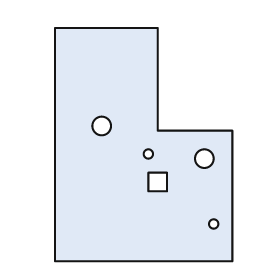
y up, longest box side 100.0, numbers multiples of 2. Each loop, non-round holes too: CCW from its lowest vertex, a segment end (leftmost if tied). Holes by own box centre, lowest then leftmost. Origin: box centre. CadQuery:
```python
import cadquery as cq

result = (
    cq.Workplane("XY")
    .moveTo(-38.0, -50.0)
    .lineTo(38.0, -50.0)
    .lineTo(38.0, 6.0)
    .lineTo(6.0, 6.0)
    .lineTo(6.0, 50.0)
    .lineTo(-38.0, 50.0)
    .close()
    .moveTo(30.0, -34.0)
    .circle(2.0)
    .moveTo(2.0, -20.0)
    .lineTo(10.0, -20.0)
    .lineTo(10.0, -12.0)
    .lineTo(2.0, -12.0)
    .close()
    .moveTo(26.0, -6.0)
    .circle(4.0)
    .moveTo(2.0, -4.0)
    .circle(2.0)
    .moveTo(-18.0, 8.0)
    .circle(4.0)
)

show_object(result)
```